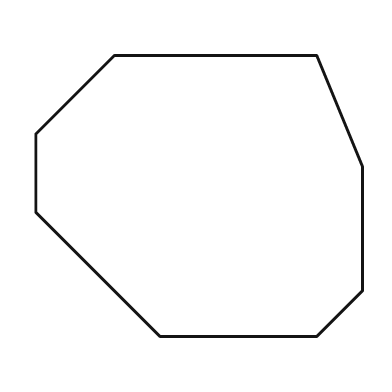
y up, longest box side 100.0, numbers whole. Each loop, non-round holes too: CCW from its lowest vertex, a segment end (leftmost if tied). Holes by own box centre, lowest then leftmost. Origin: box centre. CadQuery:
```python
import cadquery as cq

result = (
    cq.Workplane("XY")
    .moveTo(-12.0, -43.0)
    .lineTo(36.0, -43.0)
    .lineTo(50.0, -29.0)
    .lineTo(50.0, 9.0)
    .lineTo(36.0, 43.0)
    .lineTo(-26.0, 43.0)
    .lineTo(-50.0, 19.0)
    .lineTo(-50.0, -5.0)
    .close()
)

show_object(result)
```